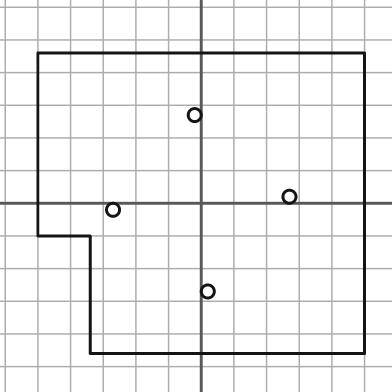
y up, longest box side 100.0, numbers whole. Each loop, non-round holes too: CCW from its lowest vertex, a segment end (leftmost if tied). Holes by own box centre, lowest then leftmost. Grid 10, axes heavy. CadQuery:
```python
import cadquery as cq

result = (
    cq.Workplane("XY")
    .moveTo(-34.0, -46.0)
    .lineTo(50.0, -46.0)
    .lineTo(50.0, 46.0)
    .lineTo(-50.0, 46.0)
    .lineTo(-50.0, -10.0)
    .lineTo(-34.0, -10.0)
    .close()
    .moveTo(2.0, -27.0)
    .circle(2.0)
    .moveTo(-27.0, -2.0)
    .circle(2.0)
    .moveTo(27.0, 2.0)
    .circle(2.0)
    .moveTo(-2.0, 27.0)
    .circle(2.0)
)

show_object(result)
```